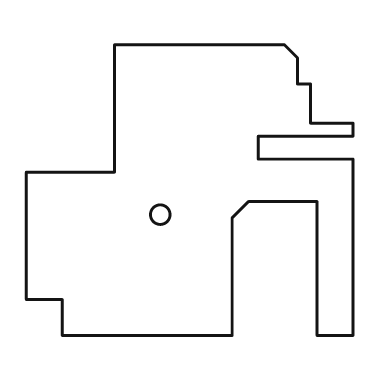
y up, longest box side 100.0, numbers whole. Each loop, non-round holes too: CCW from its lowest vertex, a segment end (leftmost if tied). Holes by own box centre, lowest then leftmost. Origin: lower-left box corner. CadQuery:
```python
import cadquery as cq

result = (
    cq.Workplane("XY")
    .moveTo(11.0, 0.0)
    .lineTo(63.0, 0.0)
    .lineTo(63.0, 36.0)
    .lineTo(68.0, 41.0)
    .lineTo(89.0, 41.0)
    .lineTo(89.0, 0.0)
    .lineTo(100.0, 0.0)
    .lineTo(100.0, 54.0)
    .lineTo(71.0, 54.0)
    .lineTo(71.0, 61.0)
    .lineTo(100.0, 61.0)
    .lineTo(100.0, 65.0)
    .lineTo(87.0, 65.0)
    .lineTo(87.0, 77.0)
    .lineTo(83.0, 77.0)
    .lineTo(83.0, 85.0)
    .lineTo(79.0, 89.0)
    .lineTo(27.0, 89.0)
    .lineTo(27.0, 50.0)
    .lineTo(0.0, 50.0)
    .lineTo(0.0, 11.0)
    .lineTo(11.0, 11.0)
    .close()
    .moveTo(41.0, 37.0)
    .circle(3.0)
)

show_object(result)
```